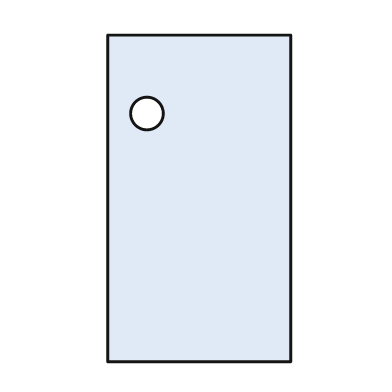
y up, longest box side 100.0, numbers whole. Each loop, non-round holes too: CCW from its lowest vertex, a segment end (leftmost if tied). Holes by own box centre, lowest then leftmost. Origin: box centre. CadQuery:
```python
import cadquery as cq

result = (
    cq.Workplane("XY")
    .moveTo(-28.0, -50.0)
    .lineTo(28.0, -50.0)
    .lineTo(28.0, 50.0)
    .lineTo(-28.0, 50.0)
    .close()
    .moveTo(-16.0, 26.0)
    .circle(5.0)
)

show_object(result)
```